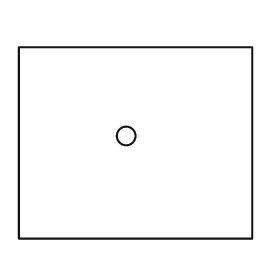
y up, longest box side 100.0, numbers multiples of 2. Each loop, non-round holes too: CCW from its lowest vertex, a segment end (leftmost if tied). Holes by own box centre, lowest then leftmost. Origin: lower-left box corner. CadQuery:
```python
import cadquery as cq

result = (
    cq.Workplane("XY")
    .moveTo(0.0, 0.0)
    .lineTo(100.0, 0.0)
    .lineTo(100.0, 82.0)
    .lineTo(0.0, 82.0)
    .close()
    .moveTo(46.0, 44.0)
    .circle(4.0)
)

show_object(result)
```